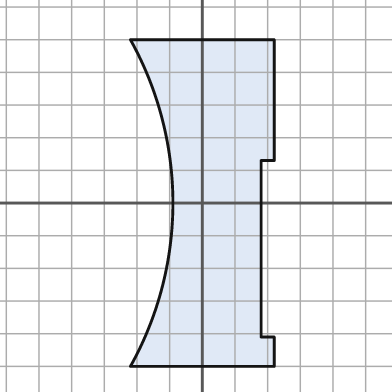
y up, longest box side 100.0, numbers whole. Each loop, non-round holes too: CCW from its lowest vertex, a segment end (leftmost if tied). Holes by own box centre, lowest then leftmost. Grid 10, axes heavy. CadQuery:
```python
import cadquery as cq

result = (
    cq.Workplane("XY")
    .moveTo(-22.0, -50.0)
    .lineTo(22.0, -50.0)
    .lineTo(22.0, -41.0)
    .lineTo(18.0, -41.0)
    .lineTo(18.0, 13.0)
    .lineTo(22.0, 13.0)
    .lineTo(22.0, 50.0)
    .lineTo(-22.0, 50.0)
    .threePointArc((-9.0, 0.0), (-22.0, -50.0))
    .close()
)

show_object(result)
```